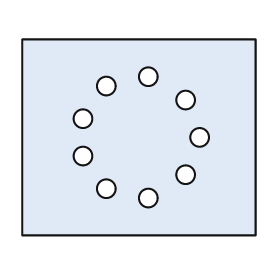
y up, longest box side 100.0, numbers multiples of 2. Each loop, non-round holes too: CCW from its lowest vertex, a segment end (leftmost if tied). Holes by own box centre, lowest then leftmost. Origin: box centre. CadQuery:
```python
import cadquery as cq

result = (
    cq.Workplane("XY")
    .moveTo(-50.0, -42.0)
    .lineTo(50.0, -42.0)
    .lineTo(50.0, 42.0)
    .lineTo(-50.0, 42.0)
    .close()
    .moveTo(4.0, -26.0)
    .circle(4.0)
    .moveTo(-14.0, -22.0)
    .circle(4.0)
    .moveTo(20.0, -16.0)
    .circle(4.0)
    .moveTo(-24.0, -8.0)
    .circle(4.0)
    .moveTo(26.0, 0.0)
    .circle(4.0)
    .moveTo(-24.0, 8.0)
    .circle(4.0)
    .moveTo(20.0, 16.0)
    .circle(4.0)
    .moveTo(-14.0, 22.0)
    .circle(4.0)
    .moveTo(4.0, 26.0)
    .circle(4.0)
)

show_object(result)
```